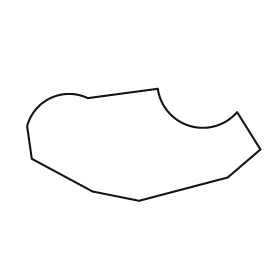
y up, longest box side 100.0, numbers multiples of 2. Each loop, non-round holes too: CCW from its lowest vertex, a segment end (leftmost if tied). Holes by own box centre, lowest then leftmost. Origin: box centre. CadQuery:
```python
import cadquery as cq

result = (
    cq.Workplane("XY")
    .moveTo(-2.0, -24.0)
    .lineTo(36.0, -14.0)
    .lineTo(50.0, -2.0)
    .lineTo(40.0, 14.0)
    .threePointArc((20.0, 8.0), (6.0, 24.0))
    .lineTo(-24.0, 20.0)
    .threePointArc((-40.0, 20.0), (-50.0, 8.0))
    .lineTo(-48.0, -6.0)
    .lineTo(-22.0, -20.0)
    .close()
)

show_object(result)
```